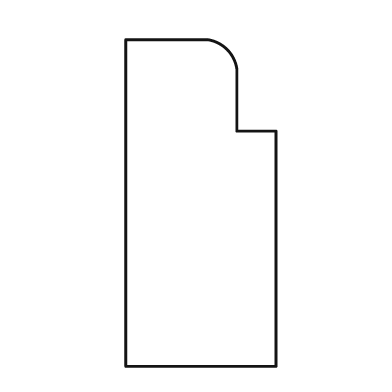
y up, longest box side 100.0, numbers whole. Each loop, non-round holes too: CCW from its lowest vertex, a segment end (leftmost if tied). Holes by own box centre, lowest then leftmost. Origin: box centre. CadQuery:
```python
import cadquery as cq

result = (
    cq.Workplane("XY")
    .moveTo(-23.0, -50.0)
    .lineTo(23.0, -50.0)
    .lineTo(23.0, 22.0)
    .lineTo(11.0, 22.0)
    .lineTo(11.0, 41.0)
    .threePointArc((8.0, 47.0), (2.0, 50.0))
    .lineTo(-23.0, 50.0)
    .close()
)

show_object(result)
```